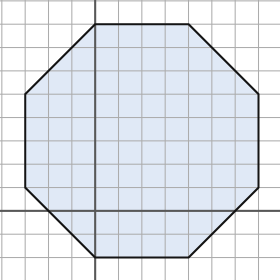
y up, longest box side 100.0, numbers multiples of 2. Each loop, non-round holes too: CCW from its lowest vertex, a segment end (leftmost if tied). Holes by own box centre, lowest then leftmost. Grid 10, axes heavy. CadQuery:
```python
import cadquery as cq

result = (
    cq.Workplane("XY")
    .moveTo(0.0, -20.0)
    .lineTo(40.0, -20.0)
    .lineTo(70.0, 10.0)
    .lineTo(70.0, 50.0)
    .lineTo(40.0, 80.0)
    .lineTo(0.0, 80.0)
    .lineTo(-30.0, 50.0)
    .lineTo(-30.0, 10.0)
    .close()
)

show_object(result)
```